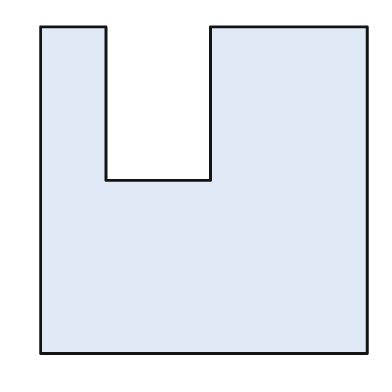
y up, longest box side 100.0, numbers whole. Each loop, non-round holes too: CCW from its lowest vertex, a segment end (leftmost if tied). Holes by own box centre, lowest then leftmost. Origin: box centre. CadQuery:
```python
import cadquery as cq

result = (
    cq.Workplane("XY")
    .moveTo(-50.0, -50.0)
    .lineTo(50.0, -50.0)
    .lineTo(50.0, 50.0)
    .lineTo(2.0, 50.0)
    .lineTo(2.0, 3.0)
    .lineTo(-30.0, 3.0)
    .lineTo(-30.0, 50.0)
    .lineTo(-50.0, 50.0)
    .close()
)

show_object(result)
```